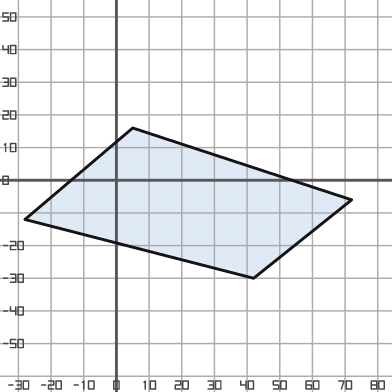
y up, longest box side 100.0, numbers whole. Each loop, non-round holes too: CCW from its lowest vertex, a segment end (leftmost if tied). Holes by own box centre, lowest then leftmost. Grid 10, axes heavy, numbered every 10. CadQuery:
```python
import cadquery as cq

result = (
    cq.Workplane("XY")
    .moveTo(42.0, -30.0)
    .lineTo(72.0, -6.0)
    .lineTo(5.0, 16.0)
    .lineTo(-28.0, -12.0)
    .close()
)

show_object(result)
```